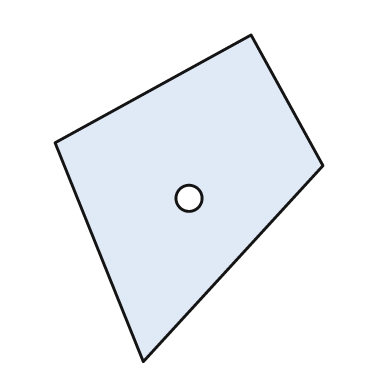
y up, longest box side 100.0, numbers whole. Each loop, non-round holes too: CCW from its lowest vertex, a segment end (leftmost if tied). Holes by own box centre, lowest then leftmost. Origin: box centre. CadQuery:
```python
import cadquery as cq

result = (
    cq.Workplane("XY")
    .moveTo(-14.0, -50.0)
    .lineTo(41.0, 10.0)
    .lineTo(19.0, 50.0)
    .lineTo(-41.0, 17.0)
    .close()
    .moveTo(0.0, 0.0)
    .circle(4.0)
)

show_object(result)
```